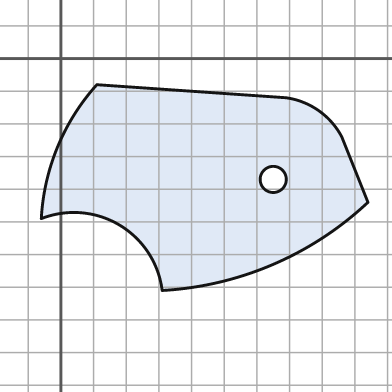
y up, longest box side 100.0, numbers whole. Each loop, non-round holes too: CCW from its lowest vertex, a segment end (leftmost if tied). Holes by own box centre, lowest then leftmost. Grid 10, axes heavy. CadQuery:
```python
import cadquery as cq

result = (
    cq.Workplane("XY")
    .moveTo(31.0, -71.0)
    .threePointArc((65.0, -63.0), (94.0, -44.0))
    .lineTo(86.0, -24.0)
    .threePointArc((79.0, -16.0), (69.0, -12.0))
    .lineTo(11.0, -8.0)
    .threePointArc((-1.0, -27.0), (-6.0, -49.0))
    .threePointArc((18.0, -51.0), (31.0, -71.0))
    .close()
    .moveTo(65.0, -37.0)
    .circle(4.0)
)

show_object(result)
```